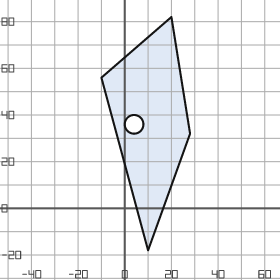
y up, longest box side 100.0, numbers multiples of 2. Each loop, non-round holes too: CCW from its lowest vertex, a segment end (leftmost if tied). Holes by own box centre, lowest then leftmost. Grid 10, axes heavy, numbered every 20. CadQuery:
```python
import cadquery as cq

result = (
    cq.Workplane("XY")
    .moveTo(10.0, -18.0)
    .lineTo(28.0, 32.0)
    .lineTo(20.0, 82.0)
    .lineTo(-10.0, 56.0)
    .close()
    .moveTo(4.0, 36.0)
    .circle(4.0)
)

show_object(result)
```